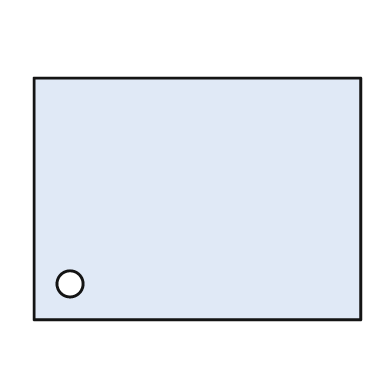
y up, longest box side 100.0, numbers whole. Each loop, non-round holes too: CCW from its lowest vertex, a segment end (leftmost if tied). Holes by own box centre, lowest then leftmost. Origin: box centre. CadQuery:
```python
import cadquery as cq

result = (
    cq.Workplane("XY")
    .moveTo(-50.0, -37.0)
    .lineTo(50.0, -37.0)
    .lineTo(50.0, 37.0)
    .lineTo(-50.0, 37.0)
    .close()
    .moveTo(-39.0, -26.0)
    .circle(4.0)
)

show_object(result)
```